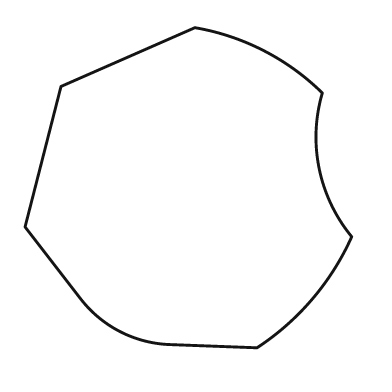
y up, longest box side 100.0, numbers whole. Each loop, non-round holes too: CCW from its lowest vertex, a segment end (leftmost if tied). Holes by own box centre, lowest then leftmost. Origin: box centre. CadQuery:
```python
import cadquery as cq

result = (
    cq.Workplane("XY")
    .moveTo(21.0, -49.0)
    .threePointArc((38.0, -34.0), (50.0, -15.0))
    .threePointArc((40.0, 6.0), (41.0, 29.0))
    .threePointArc((23.0, 42.0), (2.0, 49.0))
    .lineTo(-39.0, 31.0)
    .lineTo(-50.0, -12.0)
    .lineTo(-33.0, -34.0)
    .threePointArc((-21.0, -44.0), (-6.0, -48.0))
    .close()
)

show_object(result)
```